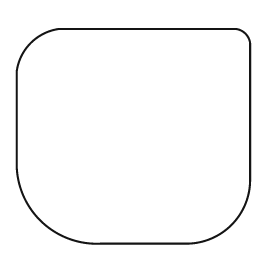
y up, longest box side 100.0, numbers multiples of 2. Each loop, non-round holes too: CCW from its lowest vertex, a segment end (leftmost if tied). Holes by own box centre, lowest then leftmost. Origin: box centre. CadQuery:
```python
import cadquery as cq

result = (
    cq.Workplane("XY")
    .moveTo(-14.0, -46.0)
    .lineTo(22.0, -46.0)
    .threePointArc((42.0, -38.0), (50.0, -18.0))
    .lineTo(50.0, 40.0)
    .threePointArc((48.0, 44.0), (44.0, 46.0))
    .lineTo(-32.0, 46.0)
    .threePointArc((-44.0, 40.0), (-50.0, 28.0))
    .lineTo(-50.0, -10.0)
    .threePointArc((-40.0, -36.0), (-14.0, -46.0))
    .close()
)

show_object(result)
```